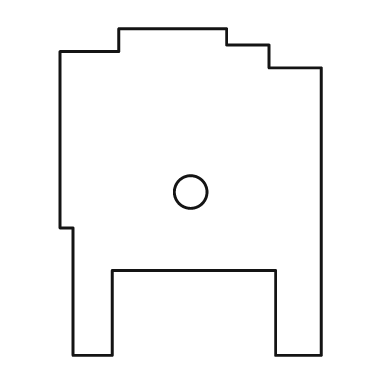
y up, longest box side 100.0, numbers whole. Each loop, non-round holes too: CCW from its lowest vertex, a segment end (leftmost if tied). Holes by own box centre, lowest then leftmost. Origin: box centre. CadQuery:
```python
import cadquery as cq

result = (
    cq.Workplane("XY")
    .moveTo(-36.0, -50.0)
    .lineTo(-24.0, -50.0)
    .lineTo(-24.0, -24.0)
    .lineTo(26.0, -24.0)
    .lineTo(26.0, -50.0)
    .lineTo(40.0, -50.0)
    .lineTo(40.0, 38.0)
    .lineTo(24.0, 38.0)
    .lineTo(24.0, 45.0)
    .lineTo(11.0, 45.0)
    .lineTo(11.0, 50.0)
    .lineTo(-22.0, 50.0)
    .lineTo(-22.0, 43.0)
    .lineTo(-40.0, 43.0)
    .lineTo(-40.0, -11.0)
    .lineTo(-36.0, -11.0)
    .close()
    .moveTo(0.0, 0.0)
    .circle(5.0)
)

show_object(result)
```